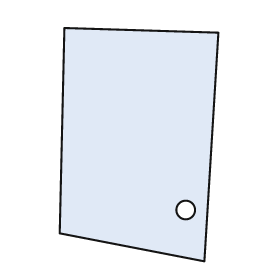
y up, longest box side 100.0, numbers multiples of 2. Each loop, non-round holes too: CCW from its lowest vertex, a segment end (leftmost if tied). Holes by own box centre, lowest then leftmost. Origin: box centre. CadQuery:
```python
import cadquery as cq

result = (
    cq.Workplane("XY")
    .moveTo(28.0, -50.0)
    .lineTo(34.0, 48.0)
    .lineTo(-32.0, 50.0)
    .lineTo(-34.0, -38.0)
    .close()
    .moveTo(20.0, -28.0)
    .circle(4.0)
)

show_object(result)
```